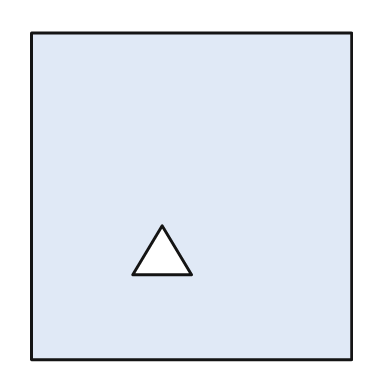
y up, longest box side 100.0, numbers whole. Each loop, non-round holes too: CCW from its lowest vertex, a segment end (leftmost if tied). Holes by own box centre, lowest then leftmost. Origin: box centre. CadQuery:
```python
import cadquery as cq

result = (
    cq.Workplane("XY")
    .moveTo(-49.0, -50.0)
    .lineTo(49.0, -50.0)
    .lineTo(49.0, 50.0)
    .lineTo(-49.0, 50.0)
    .close()
    .moveTo(-18.0, -24.0)
    .lineTo(0.0, -24.0)
    .lineTo(-9.0, -9.0)
    .close()
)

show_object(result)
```